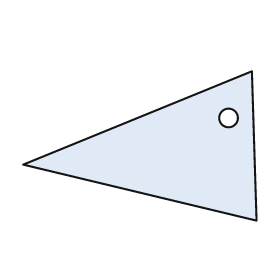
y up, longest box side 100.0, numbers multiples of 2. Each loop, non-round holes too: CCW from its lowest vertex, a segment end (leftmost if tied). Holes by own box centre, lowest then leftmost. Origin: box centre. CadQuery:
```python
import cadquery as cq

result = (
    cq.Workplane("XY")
    .moveTo(50.0, -32.0)
    .lineTo(48.0, 32.0)
    .lineTo(-50.0, -8.0)
    .close()
    .moveTo(38.0, 12.0)
    .circle(4.0)
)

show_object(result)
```